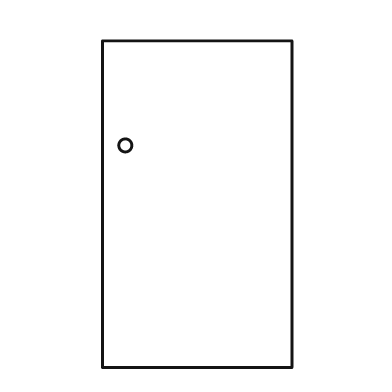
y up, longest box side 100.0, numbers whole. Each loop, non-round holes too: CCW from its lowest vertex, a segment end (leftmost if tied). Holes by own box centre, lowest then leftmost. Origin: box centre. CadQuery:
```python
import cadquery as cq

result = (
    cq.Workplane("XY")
    .moveTo(-29.0, -50.0)
    .lineTo(29.0, -50.0)
    .lineTo(29.0, 50.0)
    .lineTo(-29.0, 50.0)
    .close()
    .moveTo(-22.0, 18.0)
    .circle(2.0)
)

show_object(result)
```